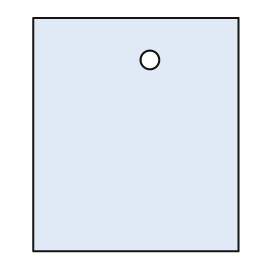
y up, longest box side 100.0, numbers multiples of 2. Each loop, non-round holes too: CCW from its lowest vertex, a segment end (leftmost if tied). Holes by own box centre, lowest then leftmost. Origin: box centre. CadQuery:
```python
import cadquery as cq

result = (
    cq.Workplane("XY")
    .moveTo(-44.0, -50.0)
    .lineTo(44.0, -50.0)
    .lineTo(44.0, 50.0)
    .lineTo(-44.0, 50.0)
    .close()
    .moveTo(6.0, 32.0)
    .circle(4.0)
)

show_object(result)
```